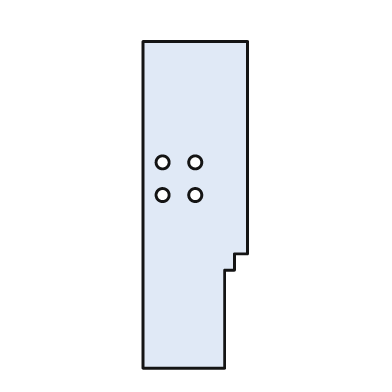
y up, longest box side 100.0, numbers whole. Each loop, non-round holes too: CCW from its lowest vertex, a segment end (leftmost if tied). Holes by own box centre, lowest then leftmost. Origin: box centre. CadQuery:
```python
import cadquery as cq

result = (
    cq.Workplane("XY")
    .moveTo(-16.0, -50.0)
    .lineTo(9.0, -50.0)
    .lineTo(9.0, -20.0)
    .lineTo(12.0, -20.0)
    .lineTo(12.0, -15.0)
    .lineTo(16.0, -15.0)
    .lineTo(16.0, 50.0)
    .lineTo(-16.0, 50.0)
    .close()
    .moveTo(-10.0, 3.0)
    .circle(2.0)
    .moveTo(0.0, 3.0)
    .circle(2.0)
    .moveTo(-10.0, 13.0)
    .circle(2.0)
    .moveTo(0.0, 13.0)
    .circle(2.0)
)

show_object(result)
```